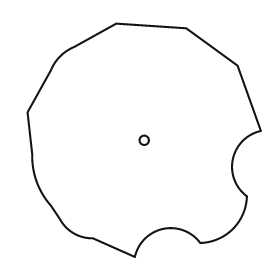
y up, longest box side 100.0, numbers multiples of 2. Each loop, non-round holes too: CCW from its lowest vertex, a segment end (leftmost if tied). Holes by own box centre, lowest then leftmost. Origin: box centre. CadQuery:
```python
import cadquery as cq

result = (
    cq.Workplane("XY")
    .moveTo(-4.0, -50.0)
    .threePointArc((8.0, -38.0), (24.0, -44.0))
    .threePointArc((38.0, -38.0), (44.0, -24.0))
    .threePointArc((38.0, -8.0), (50.0, 4.0))
    .lineTo(40.0, 32.0)
    .lineTo(18.0, 48.0)
    .lineTo(-12.0, 50.0)
    .lineTo(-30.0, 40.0)
    .threePointArc((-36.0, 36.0), (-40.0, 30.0))
    .lineTo(-50.0, 12.0)
    .lineTo(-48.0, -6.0)
    .threePointArc((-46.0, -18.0), (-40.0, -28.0))
    .lineTo(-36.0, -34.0)
    .threePointArc((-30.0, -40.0), (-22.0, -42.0))
    .close()
    .moveTo(0.0, 0.0)
    .circle(2.0)
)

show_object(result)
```